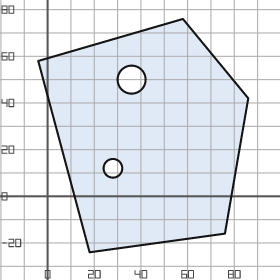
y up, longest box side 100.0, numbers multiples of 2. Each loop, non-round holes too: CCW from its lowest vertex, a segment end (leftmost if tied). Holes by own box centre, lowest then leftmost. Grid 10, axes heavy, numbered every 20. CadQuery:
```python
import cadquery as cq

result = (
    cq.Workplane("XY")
    .moveTo(18.0, -24.0)
    .lineTo(76.0, -16.0)
    .lineTo(86.0, 42.0)
    .lineTo(58.0, 76.0)
    .lineTo(-4.0, 58.0)
    .close()
    .moveTo(28.0, 12.0)
    .circle(4.0)
    .moveTo(36.0, 50.0)
    .circle(6.0)
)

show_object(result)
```